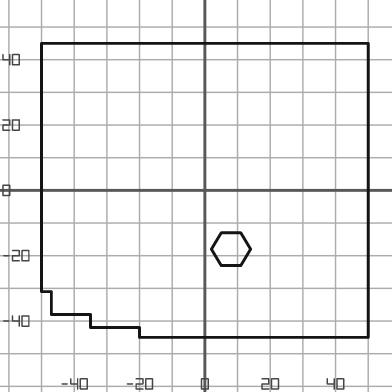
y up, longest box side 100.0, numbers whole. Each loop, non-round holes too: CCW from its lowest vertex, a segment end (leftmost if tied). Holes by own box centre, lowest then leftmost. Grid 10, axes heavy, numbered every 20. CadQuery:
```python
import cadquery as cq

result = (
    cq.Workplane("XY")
    .moveTo(-20.0, -45.0)
    .lineTo(50.0, -45.0)
    .lineTo(50.0, 45.0)
    .lineTo(-50.0, 45.0)
    .lineTo(-50.0, -31.0)
    .lineTo(-47.0, -31.0)
    .lineTo(-47.0, -38.0)
    .lineTo(-35.0, -38.0)
    .lineTo(-35.0, -42.0)
    .lineTo(-20.0, -42.0)
    .close()
    .moveTo(5.0, -23.0)
    .lineTo(11.0, -23.0)
    .lineTo(14.0, -18.0)
    .lineTo(11.0, -13.0)
    .lineTo(5.0, -13.0)
    .lineTo(2.0, -18.0)
    .close()
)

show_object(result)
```